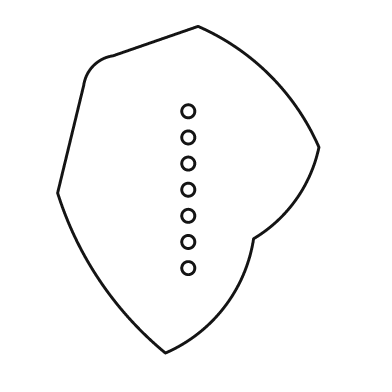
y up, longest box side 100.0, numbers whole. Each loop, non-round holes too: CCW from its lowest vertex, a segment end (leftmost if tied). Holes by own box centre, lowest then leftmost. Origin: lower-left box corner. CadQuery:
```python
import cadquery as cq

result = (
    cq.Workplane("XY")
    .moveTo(33.0, 0.0)
    .threePointArc((51.0, 14.0), (60.0, 35.0))
    .threePointArc((73.0, 47.0), (80.0, 63.0))
    .threePointArc((65.0, 85.0), (43.0, 100.0))
    .lineTo(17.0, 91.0)
    .threePointArc((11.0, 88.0), (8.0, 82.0))
    .lineTo(0.0, 49.0)
    .threePointArc((13.0, 22.0), (33.0, 0.0))
    .close()
    .moveTo(40.0, 26.0)
    .circle(2.0)
    .moveTo(40.0, 34.0)
    .circle(2.0)
    .moveTo(40.0, 42.0)
    .circle(2.0)
    .moveTo(40.0, 50.0)
    .circle(2.0)
    .moveTo(40.0, 58.0)
    .circle(2.0)
    .moveTo(40.0, 66.0)
    .circle(2.0)
    .moveTo(40.0, 74.0)
    .circle(2.0)
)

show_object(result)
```